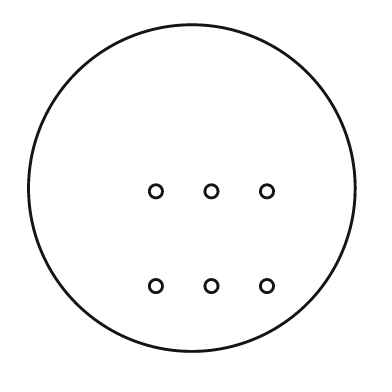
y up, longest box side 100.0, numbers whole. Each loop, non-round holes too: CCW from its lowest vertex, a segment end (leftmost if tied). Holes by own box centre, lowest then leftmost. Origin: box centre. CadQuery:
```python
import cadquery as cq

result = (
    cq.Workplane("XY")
    .moveTo(0.0, 0.0)
    .circle(50.0)
    .moveTo(-11.0, -30.0)
    .circle(2.0)
    .moveTo(6.0, -30.0)
    .circle(2.0)
    .moveTo(23.0, -30.0)
    .circle(2.0)
    .moveTo(-11.0, -1.0)
    .circle(2.0)
    .moveTo(6.0, -1.0)
    .circle(2.0)
    .moveTo(23.0, -1.0)
    .circle(2.0)
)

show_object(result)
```